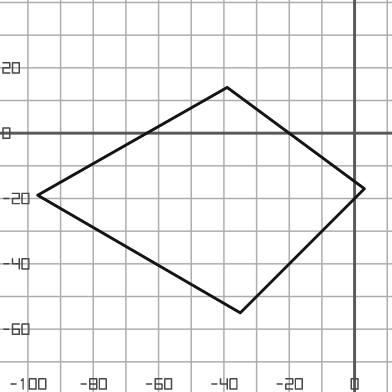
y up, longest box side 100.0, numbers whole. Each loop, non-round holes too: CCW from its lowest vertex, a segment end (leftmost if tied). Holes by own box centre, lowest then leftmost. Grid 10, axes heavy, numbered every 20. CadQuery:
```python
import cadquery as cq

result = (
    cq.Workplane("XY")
    .moveTo(-35.0, -55.0)
    .lineTo(3.0, -17.0)
    .lineTo(-39.0, 14.0)
    .lineTo(-97.0, -19.0)
    .close()
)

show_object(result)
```